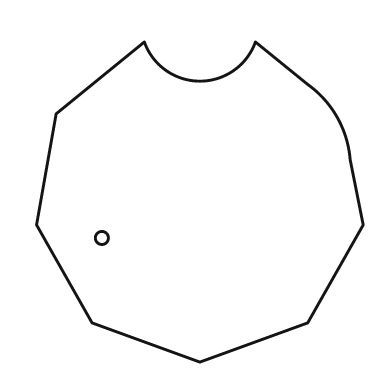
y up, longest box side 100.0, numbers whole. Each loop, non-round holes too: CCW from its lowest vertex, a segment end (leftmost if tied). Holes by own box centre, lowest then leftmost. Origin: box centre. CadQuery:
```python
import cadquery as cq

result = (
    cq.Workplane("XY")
    .moveTo(0.0, -49.0)
    .lineTo(33.0, -37.0)
    .lineTo(50.0, -7.0)
    .lineTo(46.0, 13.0)
    .threePointArc((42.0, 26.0), (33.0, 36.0))
    .lineTo(17.0, 49.0)
    .threePointArc((0.0, 37.0), (-17.0, 49.0))
    .lineTo(-44.0, 27.0)
    .lineTo(-50.0, -7.0)
    .lineTo(-33.0, -37.0)
    .close()
    .moveTo(-30.0, -11.0)
    .circle(2.0)
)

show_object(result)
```